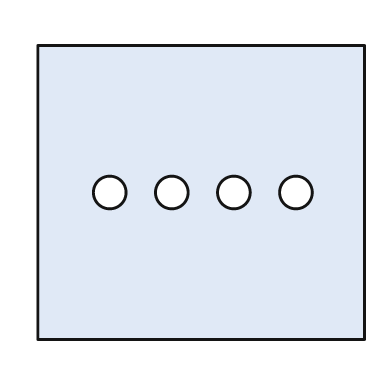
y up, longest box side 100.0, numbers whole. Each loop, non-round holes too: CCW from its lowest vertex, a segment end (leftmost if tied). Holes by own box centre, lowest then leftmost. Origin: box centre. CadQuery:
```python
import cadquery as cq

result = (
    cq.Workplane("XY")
    .moveTo(-50.0, -45.0)
    .lineTo(50.0, -45.0)
    .lineTo(50.0, 45.0)
    .lineTo(-50.0, 45.0)
    .close()
    .moveTo(-28.0, 0.0)
    .circle(5.0)
    .moveTo(-9.0, 0.0)
    .circle(5.0)
    .moveTo(10.0, 0.0)
    .circle(5.0)
    .moveTo(29.0, 0.0)
    .circle(5.0)
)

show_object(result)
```